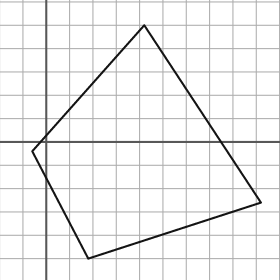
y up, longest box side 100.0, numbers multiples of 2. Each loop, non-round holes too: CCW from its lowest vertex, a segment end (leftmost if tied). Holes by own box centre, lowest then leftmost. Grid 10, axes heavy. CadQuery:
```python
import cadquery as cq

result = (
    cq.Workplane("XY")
    .moveTo(18.0, -50.0)
    .lineTo(92.0, -26.0)
    .lineTo(42.0, 50.0)
    .lineTo(-6.0, -4.0)
    .close()
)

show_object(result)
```